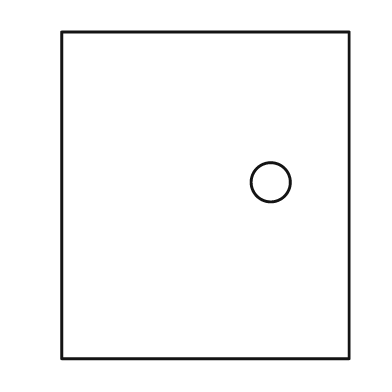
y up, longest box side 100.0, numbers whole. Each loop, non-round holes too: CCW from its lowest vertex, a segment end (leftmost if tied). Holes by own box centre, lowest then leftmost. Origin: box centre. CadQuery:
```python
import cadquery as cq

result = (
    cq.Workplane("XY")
    .moveTo(-44.0, -50.0)
    .lineTo(44.0, -50.0)
    .lineTo(44.0, 50.0)
    .lineTo(-44.0, 50.0)
    .close()
    .moveTo(20.0, 4.0)
    .circle(6.0)
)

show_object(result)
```